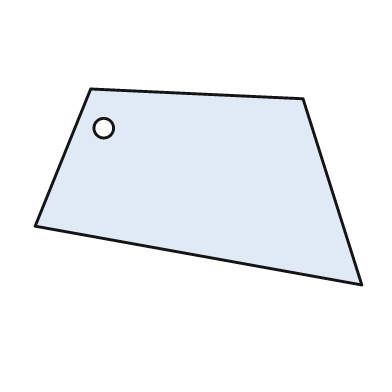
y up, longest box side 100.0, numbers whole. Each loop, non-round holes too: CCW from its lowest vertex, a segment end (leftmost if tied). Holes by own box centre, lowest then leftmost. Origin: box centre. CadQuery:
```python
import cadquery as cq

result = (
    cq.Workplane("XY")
    .moveTo(50.0, -30.0)
    .lineTo(32.0, 27.0)
    .lineTo(-33.0, 30.0)
    .lineTo(-50.0, -12.0)
    .close()
    .moveTo(-29.0, 18.0)
    .circle(3.0)
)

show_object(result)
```